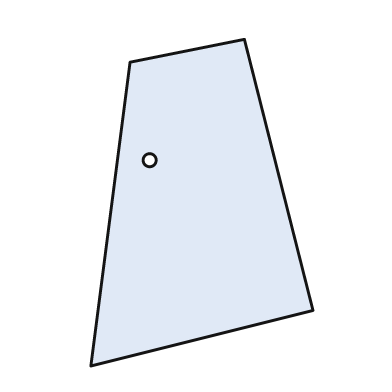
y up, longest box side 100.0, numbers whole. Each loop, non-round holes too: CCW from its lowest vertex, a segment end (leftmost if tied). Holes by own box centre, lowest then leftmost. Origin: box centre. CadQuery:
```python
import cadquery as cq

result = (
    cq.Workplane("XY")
    .moveTo(-34.0, -50.0)
    .lineTo(34.0, -33.0)
    .lineTo(13.0, 50.0)
    .lineTo(-22.0, 43.0)
    .close()
    .moveTo(-16.0, 13.0)
    .circle(2.0)
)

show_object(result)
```